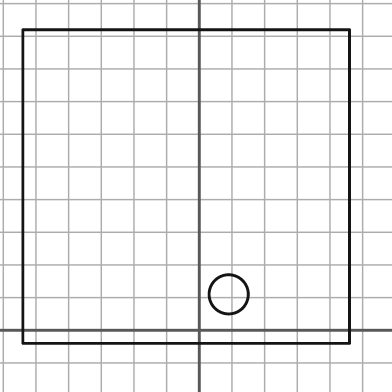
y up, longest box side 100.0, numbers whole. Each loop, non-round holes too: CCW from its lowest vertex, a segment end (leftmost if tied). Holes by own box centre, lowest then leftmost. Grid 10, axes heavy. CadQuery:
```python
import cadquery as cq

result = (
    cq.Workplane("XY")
    .moveTo(-54.0, -4.0)
    .lineTo(46.0, -4.0)
    .lineTo(46.0, 92.0)
    .lineTo(-54.0, 92.0)
    .close()
    .moveTo(9.0, 11.0)
    .circle(6.0)
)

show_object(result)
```